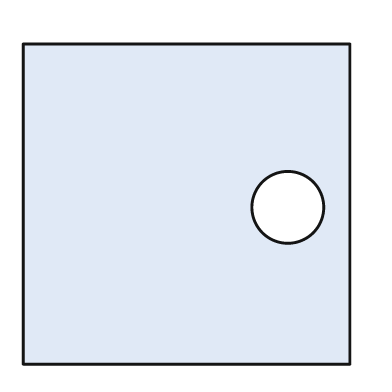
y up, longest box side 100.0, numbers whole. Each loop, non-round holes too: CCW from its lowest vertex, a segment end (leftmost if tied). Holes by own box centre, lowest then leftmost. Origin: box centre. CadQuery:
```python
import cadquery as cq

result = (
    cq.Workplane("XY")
    .moveTo(-50.0, -49.0)
    .lineTo(50.0, -49.0)
    .lineTo(50.0, 49.0)
    .lineTo(-50.0, 49.0)
    .close()
    .moveTo(31.0, -1.0)
    .circle(11.0)
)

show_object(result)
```